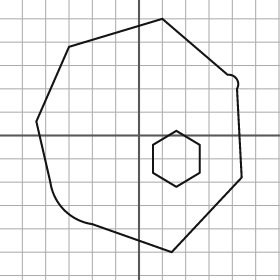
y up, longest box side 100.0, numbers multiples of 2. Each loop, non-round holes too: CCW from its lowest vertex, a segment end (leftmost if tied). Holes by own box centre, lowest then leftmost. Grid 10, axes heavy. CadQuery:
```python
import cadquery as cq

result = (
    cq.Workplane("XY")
    .moveTo(14.0, -50.0)
    .lineTo(44.0, -18.0)
    .lineTo(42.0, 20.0)
    .threePointArc((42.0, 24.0), (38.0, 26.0))
    .lineTo(10.0, 50.0)
    .lineTo(-30.0, 38.0)
    .lineTo(-44.0, 6.0)
    .lineTo(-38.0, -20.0)
    .threePointArc((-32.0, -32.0), (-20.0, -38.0))
    .close()
    .moveTo(16.0, -22.0)
    .lineTo(26.0, -16.0)
    .lineTo(26.0, -4.0)
    .lineTo(16.0, 2.0)
    .lineTo(6.0, -4.0)
    .lineTo(6.0, -16.0)
    .close()
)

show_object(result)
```